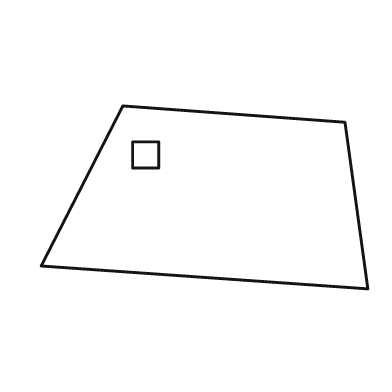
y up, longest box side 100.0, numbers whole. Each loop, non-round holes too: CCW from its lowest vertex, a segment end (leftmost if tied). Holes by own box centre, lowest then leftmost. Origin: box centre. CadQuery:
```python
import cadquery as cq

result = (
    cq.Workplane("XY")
    .moveTo(50.0, -28.0)
    .lineTo(43.0, 23.0)
    .lineTo(-25.0, 28.0)
    .lineTo(-50.0, -21.0)
    .close()
    .moveTo(-22.0, 9.0)
    .lineTo(-14.0, 9.0)
    .lineTo(-14.0, 17.0)
    .lineTo(-22.0, 17.0)
    .close()
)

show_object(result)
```